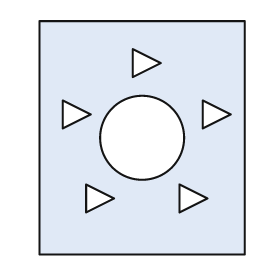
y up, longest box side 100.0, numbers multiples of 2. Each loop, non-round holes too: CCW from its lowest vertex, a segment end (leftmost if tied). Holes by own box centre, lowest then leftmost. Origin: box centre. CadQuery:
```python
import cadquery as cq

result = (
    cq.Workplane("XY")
    .moveTo(-44.0, -50.0)
    .lineTo(44.0, -50.0)
    .lineTo(44.0, 50.0)
    .lineTo(-44.0, 50.0)
    .close()
    .moveTo(-24.0, -32.0)
    .lineTo(-12.0, -26.0)
    .lineTo(-24.0, -20.0)
    .close()
    .moveTo(16.0, -32.0)
    .lineTo(28.0, -26.0)
    .lineTo(16.0, -20.0)
    .close()
    .moveTo(0.0, 0.0)
    .circle(18.0)
    .moveTo(-34.0, 4.0)
    .lineTo(-22.0, 10.0)
    .lineTo(-34.0, 16.0)
    .close()
    .moveTo(26.0, 4.0)
    .lineTo(38.0, 10.0)
    .lineTo(26.0, 16.0)
    .close()
    .moveTo(-4.0, 26.0)
    .lineTo(8.0, 32.0)
    .lineTo(-4.0, 38.0)
    .close()
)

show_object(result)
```